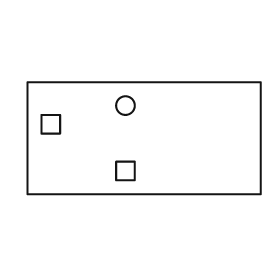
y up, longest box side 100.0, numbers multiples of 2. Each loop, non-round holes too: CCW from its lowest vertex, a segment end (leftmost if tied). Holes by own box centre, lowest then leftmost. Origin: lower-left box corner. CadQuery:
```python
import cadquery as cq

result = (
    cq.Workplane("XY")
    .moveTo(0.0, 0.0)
    .lineTo(100.0, 0.0)
    .lineTo(100.0, 48.0)
    .lineTo(0.0, 48.0)
    .close()
    .moveTo(38.0, 6.0)
    .lineTo(46.0, 6.0)
    .lineTo(46.0, 14.0)
    .lineTo(38.0, 14.0)
    .close()
    .moveTo(6.0, 26.0)
    .lineTo(14.0, 26.0)
    .lineTo(14.0, 34.0)
    .lineTo(6.0, 34.0)
    .close()
    .moveTo(42.0, 38.0)
    .circle(4.0)
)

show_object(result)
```